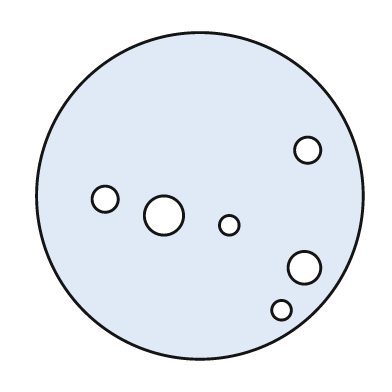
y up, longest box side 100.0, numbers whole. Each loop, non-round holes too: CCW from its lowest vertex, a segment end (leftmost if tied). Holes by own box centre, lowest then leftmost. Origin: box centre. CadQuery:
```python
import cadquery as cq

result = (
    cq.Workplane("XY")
    .moveTo(0.0, 0.0)
    .circle(50.0)
    .moveTo(25.0, -35.0)
    .circle(3.0)
    .moveTo(32.0, -22.0)
    .circle(5.0)
    .moveTo(9.0, -9.0)
    .circle(3.0)
    .moveTo(-11.0, -6.0)
    .circle(6.0)
    .moveTo(-29.0, -1.0)
    .circle(4.0)
    .moveTo(33.0, 14.0)
    .circle(4.0)
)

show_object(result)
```